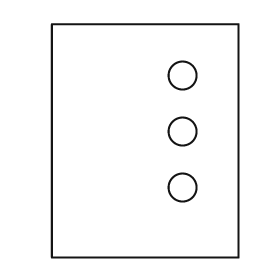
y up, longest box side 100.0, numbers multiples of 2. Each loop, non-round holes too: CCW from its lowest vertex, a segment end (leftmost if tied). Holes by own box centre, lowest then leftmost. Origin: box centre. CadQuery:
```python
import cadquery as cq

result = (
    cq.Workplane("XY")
    .moveTo(-40.0, -50.0)
    .lineTo(40.0, -50.0)
    .lineTo(40.0, 50.0)
    .lineTo(-40.0, 50.0)
    .close()
    .moveTo(16.0, -20.0)
    .circle(6.0)
    .moveTo(16.0, 4.0)
    .circle(6.0)
    .moveTo(16.0, 28.0)
    .circle(6.0)
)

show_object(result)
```